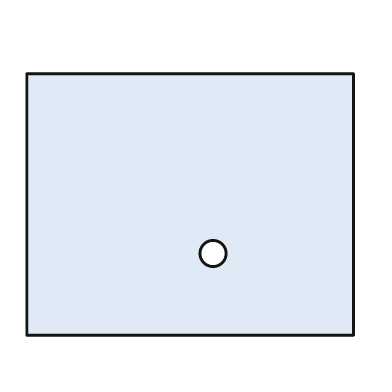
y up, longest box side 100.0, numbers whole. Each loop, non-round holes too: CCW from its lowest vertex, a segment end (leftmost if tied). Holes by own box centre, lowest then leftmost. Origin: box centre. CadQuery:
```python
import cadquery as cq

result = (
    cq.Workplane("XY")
    .moveTo(-50.0, -40.0)
    .lineTo(50.0, -40.0)
    .lineTo(50.0, 40.0)
    .lineTo(-50.0, 40.0)
    .close()
    .moveTo(7.0, -15.0)
    .circle(4.0)
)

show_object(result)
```